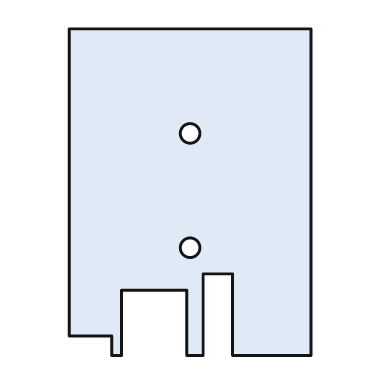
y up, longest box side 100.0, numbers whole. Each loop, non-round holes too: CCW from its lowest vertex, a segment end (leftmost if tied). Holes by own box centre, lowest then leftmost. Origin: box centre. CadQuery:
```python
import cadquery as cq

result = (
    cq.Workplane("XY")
    .moveTo(-24.0, -50.0)
    .lineTo(-21.0, -50.0)
    .lineTo(-21.0, -30.0)
    .lineTo(-1.0, -30.0)
    .lineTo(-1.0, -50.0)
    .lineTo(4.0, -50.0)
    .lineTo(4.0, -25.0)
    .lineTo(13.0, -25.0)
    .lineTo(13.0, -50.0)
    .lineTo(37.0, -50.0)
    .lineTo(37.0, 50.0)
    .lineTo(-37.0, 50.0)
    .lineTo(-37.0, -44.0)
    .lineTo(-24.0, -44.0)
    .close()
    .moveTo(0.0, -17.0)
    .circle(3.0)
    .moveTo(0.0, 18.0)
    .circle(3.0)
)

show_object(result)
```